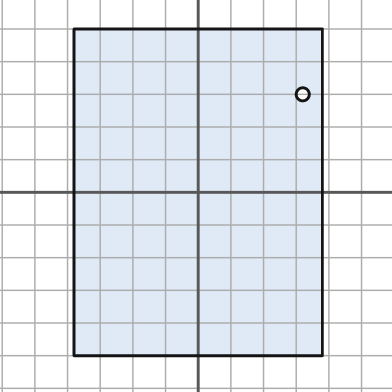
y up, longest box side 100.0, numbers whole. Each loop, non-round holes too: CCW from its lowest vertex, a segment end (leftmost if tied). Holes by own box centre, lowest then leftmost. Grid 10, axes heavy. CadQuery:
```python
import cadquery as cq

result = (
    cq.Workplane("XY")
    .moveTo(-38.0, -50.0)
    .lineTo(38.0, -50.0)
    .lineTo(38.0, 50.0)
    .lineTo(-38.0, 50.0)
    .close()
    .moveTo(32.0, 30.0)
    .circle(2.0)
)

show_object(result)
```